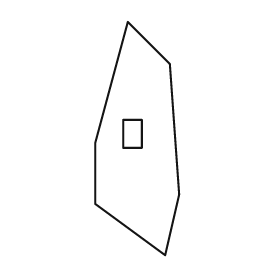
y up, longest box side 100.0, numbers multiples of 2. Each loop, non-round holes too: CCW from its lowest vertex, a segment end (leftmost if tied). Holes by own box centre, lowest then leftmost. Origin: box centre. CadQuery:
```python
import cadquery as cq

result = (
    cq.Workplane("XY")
    .moveTo(12.0, -50.0)
    .lineTo(18.0, -24.0)
    .lineTo(14.0, 32.0)
    .lineTo(-4.0, 50.0)
    .lineTo(-18.0, -2.0)
    .lineTo(-18.0, -28.0)
    .close()
    .moveTo(-6.0, -4.0)
    .lineTo(2.0, -4.0)
    .lineTo(2.0, 8.0)
    .lineTo(-6.0, 8.0)
    .close()
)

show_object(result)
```